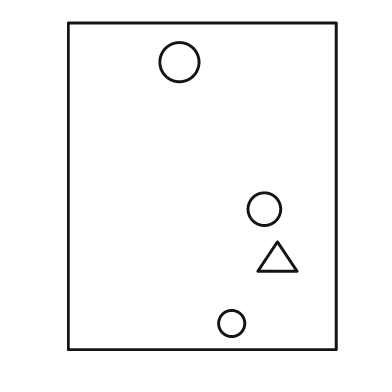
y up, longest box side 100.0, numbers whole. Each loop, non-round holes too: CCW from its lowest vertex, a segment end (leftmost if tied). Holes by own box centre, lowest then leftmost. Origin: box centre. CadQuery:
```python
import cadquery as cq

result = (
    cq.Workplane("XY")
    .moveTo(-41.0, -50.0)
    .lineTo(41.0, -50.0)
    .lineTo(41.0, 50.0)
    .lineTo(-41.0, 50.0)
    .close()
    .moveTo(9.0, -42.0)
    .circle(4.0)
    .moveTo(17.0, -26.0)
    .lineTo(29.0, -26.0)
    .lineTo(23.0, -17.0)
    .close()
    .moveTo(19.0, -7.0)
    .circle(5.0)
    .moveTo(-7.0, 38.0)
    .circle(6.0)
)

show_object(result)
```